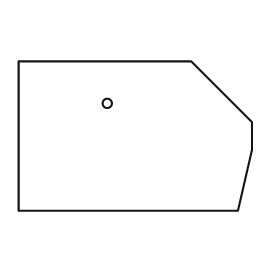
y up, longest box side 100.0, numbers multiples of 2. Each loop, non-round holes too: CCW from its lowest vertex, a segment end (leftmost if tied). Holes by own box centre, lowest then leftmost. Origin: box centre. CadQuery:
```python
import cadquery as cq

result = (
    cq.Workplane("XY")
    .moveTo(-50.0, -32.0)
    .lineTo(44.0, -32.0)
    .lineTo(50.0, -6.0)
    .lineTo(50.0, 6.0)
    .lineTo(24.0, 32.0)
    .lineTo(-50.0, 32.0)
    .close()
    .moveTo(-12.0, 14.0)
    .circle(2.0)
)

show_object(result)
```